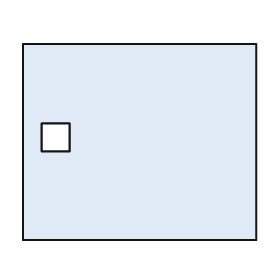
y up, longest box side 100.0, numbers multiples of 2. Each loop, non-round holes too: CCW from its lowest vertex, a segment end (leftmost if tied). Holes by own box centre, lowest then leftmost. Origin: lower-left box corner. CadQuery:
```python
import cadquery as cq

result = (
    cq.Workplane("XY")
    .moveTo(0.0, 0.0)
    .lineTo(100.0, 0.0)
    .lineTo(100.0, 84.0)
    .lineTo(0.0, 84.0)
    .close()
    .moveTo(8.0, 38.0)
    .lineTo(20.0, 38.0)
    .lineTo(20.0, 50.0)
    .lineTo(8.0, 50.0)
    .close()
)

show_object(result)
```